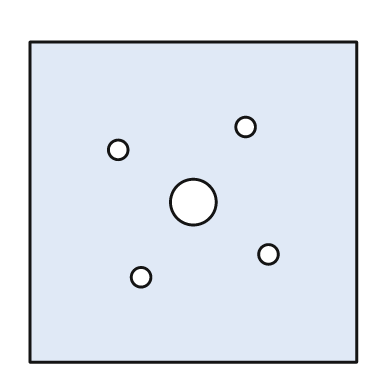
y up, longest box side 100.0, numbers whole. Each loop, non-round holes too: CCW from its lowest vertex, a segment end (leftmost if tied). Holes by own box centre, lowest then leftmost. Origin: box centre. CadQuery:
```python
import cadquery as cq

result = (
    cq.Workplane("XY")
    .moveTo(-50.0, -49.0)
    .lineTo(50.0, -49.0)
    .lineTo(50.0, 49.0)
    .lineTo(-50.0, 49.0)
    .close()
    .moveTo(-16.0, -23.0)
    .circle(3.0)
    .moveTo(23.0, -16.0)
    .circle(3.0)
    .moveTo(0.0, 0.0)
    .circle(7.0)
    .moveTo(-23.0, 16.0)
    .circle(3.0)
    .moveTo(16.0, 23.0)
    .circle(3.0)
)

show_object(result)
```